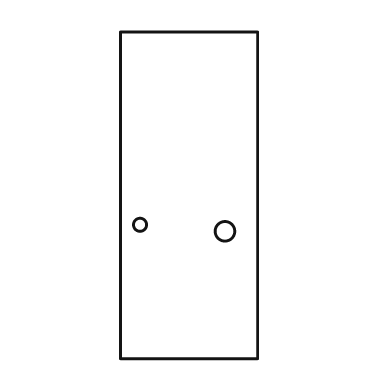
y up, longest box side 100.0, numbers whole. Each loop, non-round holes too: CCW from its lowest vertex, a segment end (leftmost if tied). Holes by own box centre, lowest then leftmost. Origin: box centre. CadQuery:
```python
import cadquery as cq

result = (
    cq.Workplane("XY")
    .moveTo(-21.0, -50.0)
    .lineTo(21.0, -50.0)
    .lineTo(21.0, 50.0)
    .lineTo(-21.0, 50.0)
    .close()
    .moveTo(11.0, -11.0)
    .circle(3.0)
    .moveTo(-15.0, -9.0)
    .circle(2.0)
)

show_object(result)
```